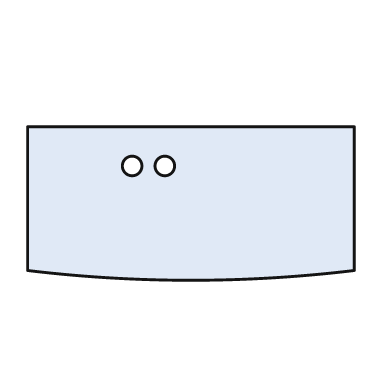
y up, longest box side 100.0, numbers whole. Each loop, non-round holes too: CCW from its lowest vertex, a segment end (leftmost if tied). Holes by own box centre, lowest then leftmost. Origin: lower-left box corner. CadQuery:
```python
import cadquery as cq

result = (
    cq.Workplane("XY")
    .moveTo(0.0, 3.0)
    .threePointArc((50.0, 0.0), (100.0, 3.0))
    .lineTo(100.0, 47.0)
    .lineTo(0.0, 47.0)
    .close()
    .moveTo(32.0, 35.0)
    .circle(3.0)
    .moveTo(42.0, 35.0)
    .circle(3.0)
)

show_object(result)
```